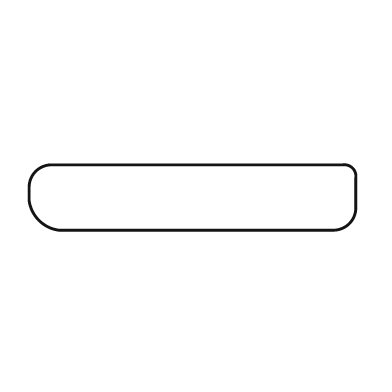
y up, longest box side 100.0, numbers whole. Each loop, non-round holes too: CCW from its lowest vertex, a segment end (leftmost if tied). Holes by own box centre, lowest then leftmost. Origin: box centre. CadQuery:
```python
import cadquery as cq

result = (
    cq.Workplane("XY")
    .moveTo(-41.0, -10.0)
    .lineTo(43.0, -10.0)
    .threePointArc((48.0, -8.0), (50.0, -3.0))
    .lineTo(50.0, 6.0)
    .threePointArc((49.0, 9.0), (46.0, 10.0))
    .lineTo(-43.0, 10.0)
    .threePointArc((-48.0, 8.0), (-50.0, 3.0))
    .lineTo(-50.0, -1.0)
    .threePointArc((-47.0, -7.0), (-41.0, -10.0))
    .close()
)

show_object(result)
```